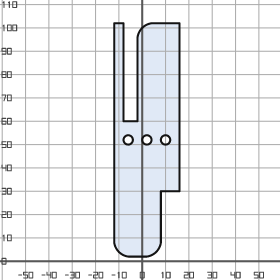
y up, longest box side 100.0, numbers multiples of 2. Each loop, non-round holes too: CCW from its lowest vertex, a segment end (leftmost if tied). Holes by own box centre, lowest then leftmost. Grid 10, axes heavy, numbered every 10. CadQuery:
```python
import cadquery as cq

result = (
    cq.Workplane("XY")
    .moveTo(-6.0, 2.0)
    .lineTo(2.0, 2.0)
    .threePointArc((6.0, 4.0), (8.0, 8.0))
    .lineTo(8.0, 30.0)
    .lineTo(16.0, 30.0)
    .lineTo(16.0, 102.0)
    .lineTo(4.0, 102.0)
    .threePointArc((0.0, 100.0), (-2.0, 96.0))
    .lineTo(-2.0, 60.0)
    .lineTo(-8.0, 60.0)
    .lineTo(-8.0, 102.0)
    .lineTo(-12.0, 102.0)
    .lineTo(-12.0, 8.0)
    .threePointArc((-10.0, 4.0), (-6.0, 2.0))
    .close()
    .moveTo(-6.0, 52.0)
    .circle(2.0)
    .moveTo(2.0, 52.0)
    .circle(2.0)
    .moveTo(10.0, 52.0)
    .circle(2.0)
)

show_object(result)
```